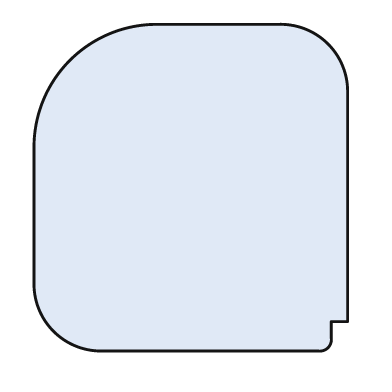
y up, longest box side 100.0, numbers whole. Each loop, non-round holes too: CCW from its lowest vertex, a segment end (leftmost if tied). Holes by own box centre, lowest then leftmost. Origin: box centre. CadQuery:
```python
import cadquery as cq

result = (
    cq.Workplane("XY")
    .moveTo(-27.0, -50.0)
    .lineTo(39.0, -50.0)
    .threePointArc((42.0, -49.0), (43.0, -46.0))
    .lineTo(43.0, -41.0)
    .lineTo(48.0, -41.0)
    .lineTo(48.0, 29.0)
    .threePointArc((42.0, 44.0), (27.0, 50.0))
    .lineTo(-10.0, 50.0)
    .threePointArc((-37.0, 39.0), (-48.0, 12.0))
    .lineTo(-48.0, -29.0)
    .threePointArc((-42.0, -44.0), (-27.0, -50.0))
    .close()
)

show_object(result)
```